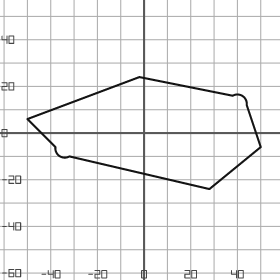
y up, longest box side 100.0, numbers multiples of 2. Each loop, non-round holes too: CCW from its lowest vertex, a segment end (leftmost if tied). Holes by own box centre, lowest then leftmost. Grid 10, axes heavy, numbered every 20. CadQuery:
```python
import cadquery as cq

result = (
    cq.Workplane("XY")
    .moveTo(28.0, -24.0)
    .lineTo(50.0, -6.0)
    .lineTo(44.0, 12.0)
    .threePointArc((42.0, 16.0), (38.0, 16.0))
    .lineTo(-2.0, 24.0)
    .lineTo(-50.0, 6.0)
    .lineTo(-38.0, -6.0)
    .threePointArc((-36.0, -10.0), (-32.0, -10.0))
    .close()
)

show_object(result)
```